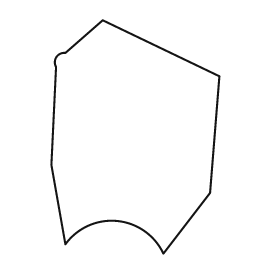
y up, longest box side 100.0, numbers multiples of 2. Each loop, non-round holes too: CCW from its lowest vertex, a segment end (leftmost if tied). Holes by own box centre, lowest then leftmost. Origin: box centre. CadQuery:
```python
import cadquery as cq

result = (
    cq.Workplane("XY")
    .moveTo(12.0, -50.0)
    .lineTo(32.0, -24.0)
    .lineTo(36.0, 26.0)
    .lineTo(-14.0, 50.0)
    .lineTo(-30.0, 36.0)
    .threePointArc((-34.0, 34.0), (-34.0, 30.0))
    .lineTo(-36.0, -12.0)
    .lineTo(-30.0, -46.0)
    .threePointArc((-8.0, -36.0), (12.0, -50.0))
    .close()
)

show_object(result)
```